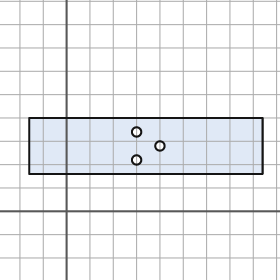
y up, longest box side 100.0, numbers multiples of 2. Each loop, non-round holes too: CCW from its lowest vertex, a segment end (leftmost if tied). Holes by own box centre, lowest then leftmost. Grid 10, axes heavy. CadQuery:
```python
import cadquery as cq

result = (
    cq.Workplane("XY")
    .moveTo(-16.0, 16.0)
    .lineTo(84.0, 16.0)
    .lineTo(84.0, 40.0)
    .lineTo(-16.0, 40.0)
    .close()
    .moveTo(30.0, 22.0)
    .circle(2.0)
    .moveTo(40.0, 28.0)
    .circle(2.0)
    .moveTo(30.0, 34.0)
    .circle(2.0)
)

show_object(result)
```